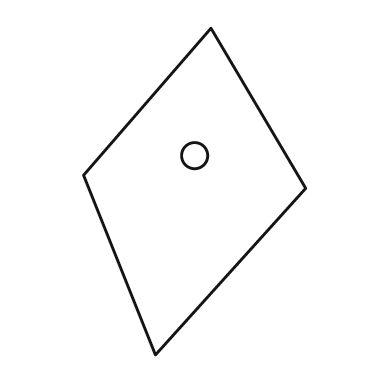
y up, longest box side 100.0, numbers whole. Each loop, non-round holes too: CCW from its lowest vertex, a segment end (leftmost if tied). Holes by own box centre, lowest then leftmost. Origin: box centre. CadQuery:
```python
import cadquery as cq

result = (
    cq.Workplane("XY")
    .moveTo(-12.0, -50.0)
    .lineTo(34.0, 1.0)
    .lineTo(5.0, 50.0)
    .lineTo(-34.0, 5.0)
    .close()
    .moveTo(0.0, 11.0)
    .circle(4.0)
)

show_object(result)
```